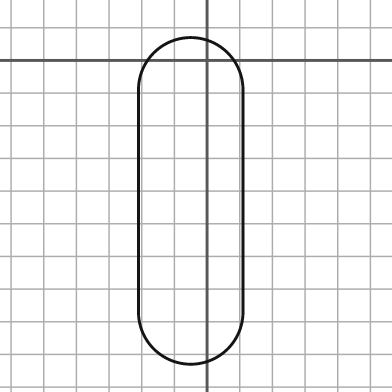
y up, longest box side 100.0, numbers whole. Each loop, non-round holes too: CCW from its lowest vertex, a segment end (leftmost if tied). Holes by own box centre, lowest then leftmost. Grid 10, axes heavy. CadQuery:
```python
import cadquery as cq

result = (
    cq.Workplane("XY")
    .moveTo(-21.0, -77.0)
    .threePointArc((-5.0, -93.0), (11.0, -77.0))
    .lineTo(11.0, -9.0)
    .threePointArc((-5.0, 7.0), (-21.0, -9.0))
    .close()
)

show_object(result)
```